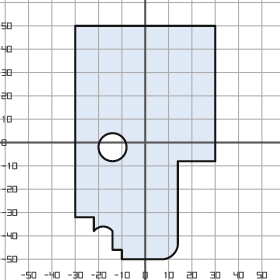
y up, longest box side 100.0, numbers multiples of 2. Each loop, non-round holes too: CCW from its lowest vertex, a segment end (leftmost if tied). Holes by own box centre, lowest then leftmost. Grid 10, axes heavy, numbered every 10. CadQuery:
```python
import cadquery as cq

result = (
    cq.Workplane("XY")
    .moveTo(-10.0, -50.0)
    .lineTo(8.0, -50.0)
    .threePointArc((12.0, -48.0), (14.0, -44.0))
    .lineTo(14.0, -8.0)
    .lineTo(30.0, -8.0)
    .lineTo(30.0, 50.0)
    .lineTo(-30.0, 50.0)
    .lineTo(-30.0, -32.0)
    .lineTo(-22.0, -32.0)
    .lineTo(-22.0, -38.0)
    .threePointArc((-18.0, -36.0), (-14.0, -38.0))
    .lineTo(-14.0, -46.0)
    .lineTo(-10.0, -46.0)
    .close()
    .moveTo(-14.0, -2.0)
    .circle(6.0)
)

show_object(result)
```